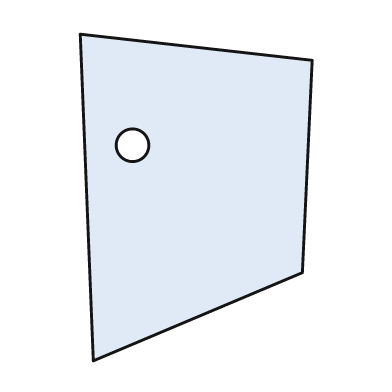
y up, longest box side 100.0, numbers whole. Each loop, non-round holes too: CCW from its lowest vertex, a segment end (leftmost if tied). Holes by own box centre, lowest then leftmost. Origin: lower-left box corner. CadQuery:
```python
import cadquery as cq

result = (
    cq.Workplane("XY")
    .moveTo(4.0, 0.0)
    .lineTo(68.0, 27.0)
    .lineTo(71.0, 92.0)
    .lineTo(0.0, 100.0)
    .close()
    .moveTo(16.0, 66.0)
    .circle(5.0)
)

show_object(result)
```